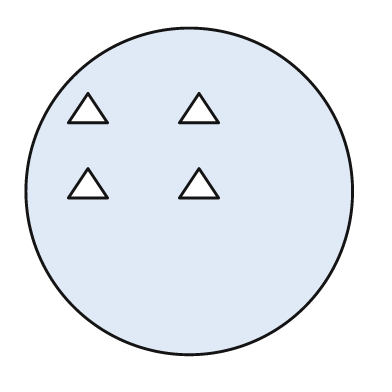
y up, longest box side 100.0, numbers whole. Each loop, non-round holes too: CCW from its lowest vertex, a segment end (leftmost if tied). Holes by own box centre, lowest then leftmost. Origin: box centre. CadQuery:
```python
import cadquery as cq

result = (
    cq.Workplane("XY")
    .moveTo(0.0, 0.0)
    .circle(50.0)
    .moveTo(-37.0, -2.0)
    .lineTo(-25.0, -2.0)
    .lineTo(-31.0, 7.0)
    .close()
    .moveTo(-3.0, -2.0)
    .lineTo(9.0, -2.0)
    .lineTo(3.0, 7.0)
    .close()
    .moveTo(-37.0, 21.0)
    .lineTo(-25.0, 21.0)
    .lineTo(-31.0, 30.0)
    .close()
    .moveTo(-3.0, 21.0)
    .lineTo(9.0, 21.0)
    .lineTo(3.0, 30.0)
    .close()
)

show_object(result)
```